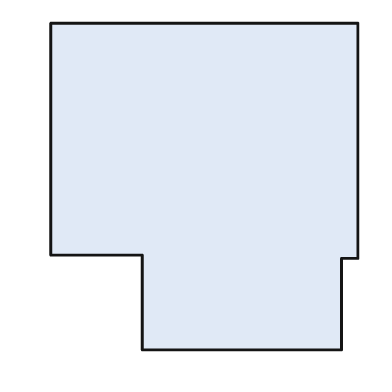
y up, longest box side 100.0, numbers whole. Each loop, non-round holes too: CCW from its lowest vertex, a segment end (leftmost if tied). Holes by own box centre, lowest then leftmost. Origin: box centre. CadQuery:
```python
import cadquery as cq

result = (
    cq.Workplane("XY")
    .moveTo(-19.0, -50.0)
    .lineTo(42.0, -50.0)
    .lineTo(42.0, -22.0)
    .lineTo(47.0, -22.0)
    .lineTo(47.0, 50.0)
    .lineTo(-47.0, 50.0)
    .lineTo(-47.0, -21.0)
    .lineTo(-19.0, -21.0)
    .close()
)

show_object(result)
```